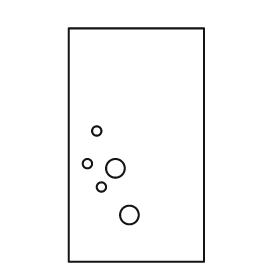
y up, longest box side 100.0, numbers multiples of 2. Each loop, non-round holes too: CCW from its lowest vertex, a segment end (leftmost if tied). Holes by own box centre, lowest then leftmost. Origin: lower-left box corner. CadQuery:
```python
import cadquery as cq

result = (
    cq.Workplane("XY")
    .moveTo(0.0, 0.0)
    .lineTo(58.0, 0.0)
    .lineTo(58.0, 100.0)
    .lineTo(0.0, 100.0)
    .close()
    .moveTo(26.0, 20.0)
    .circle(4.0)
    .moveTo(14.0, 32.0)
    .circle(2.0)
    .moveTo(20.0, 40.0)
    .circle(4.0)
    .moveTo(8.0, 42.0)
    .circle(2.0)
    .moveTo(12.0, 56.0)
    .circle(2.0)
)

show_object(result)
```